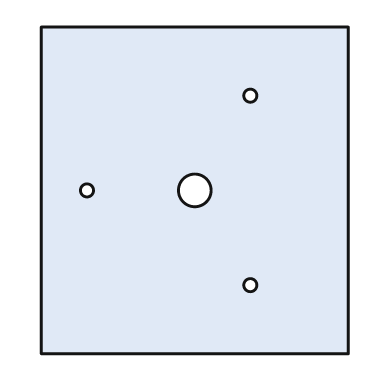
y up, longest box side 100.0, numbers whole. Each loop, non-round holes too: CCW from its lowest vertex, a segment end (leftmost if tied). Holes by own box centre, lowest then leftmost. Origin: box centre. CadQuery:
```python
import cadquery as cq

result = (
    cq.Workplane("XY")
    .moveTo(-47.0, -50.0)
    .lineTo(47.0, -50.0)
    .lineTo(47.0, 50.0)
    .lineTo(-47.0, 50.0)
    .close()
    .moveTo(17.0, -29.0)
    .circle(2.0)
    .moveTo(-33.0, 0.0)
    .circle(2.0)
    .moveTo(0.0, 0.0)
    .circle(5.0)
    .moveTo(17.0, 29.0)
    .circle(2.0)
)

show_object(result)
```